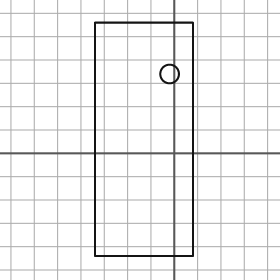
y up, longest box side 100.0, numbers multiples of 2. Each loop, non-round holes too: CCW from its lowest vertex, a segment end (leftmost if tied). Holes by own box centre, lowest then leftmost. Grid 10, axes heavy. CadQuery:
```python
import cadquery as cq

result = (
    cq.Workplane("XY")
    .moveTo(-34.0, -44.0)
    .lineTo(8.0, -44.0)
    .lineTo(8.0, 56.0)
    .lineTo(-34.0, 56.0)
    .close()
    .moveTo(-2.0, 34.0)
    .circle(4.0)
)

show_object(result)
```